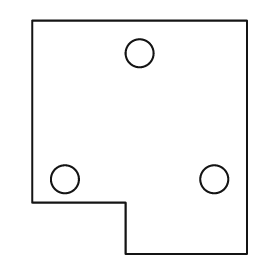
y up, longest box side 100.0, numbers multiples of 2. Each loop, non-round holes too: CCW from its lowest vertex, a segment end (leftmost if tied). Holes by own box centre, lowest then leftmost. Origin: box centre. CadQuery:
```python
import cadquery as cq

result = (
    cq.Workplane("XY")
    .moveTo(-6.0, -50.0)
    .lineTo(46.0, -50.0)
    .lineTo(46.0, 50.0)
    .lineTo(-46.0, 50.0)
    .lineTo(-46.0, -28.0)
    .lineTo(-6.0, -28.0)
    .close()
    .moveTo(-32.0, -18.0)
    .circle(6.0)
    .moveTo(32.0, -18.0)
    .circle(6.0)
    .moveTo(0.0, 36.0)
    .circle(6.0)
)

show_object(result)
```